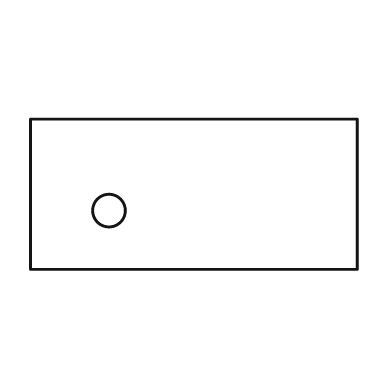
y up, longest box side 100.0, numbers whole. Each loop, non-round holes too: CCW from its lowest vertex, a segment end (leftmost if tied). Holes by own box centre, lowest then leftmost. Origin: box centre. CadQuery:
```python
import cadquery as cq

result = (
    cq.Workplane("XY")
    .moveTo(-50.0, -23.0)
    .lineTo(50.0, -23.0)
    .lineTo(50.0, 23.0)
    .lineTo(-50.0, 23.0)
    .close()
    .moveTo(-26.0, -5.0)
    .circle(5.0)
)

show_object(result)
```